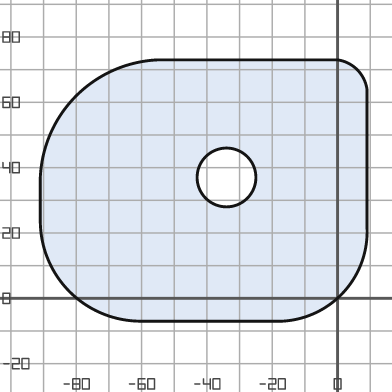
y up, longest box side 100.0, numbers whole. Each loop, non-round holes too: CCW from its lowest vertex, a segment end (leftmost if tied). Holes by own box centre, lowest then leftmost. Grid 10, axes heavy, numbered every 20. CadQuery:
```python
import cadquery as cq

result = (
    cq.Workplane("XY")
    .moveTo(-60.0, -7.0)
    .lineTo(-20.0, -7.0)
    .threePointArc((1.0, 1.0), (9.0, 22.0))
    .lineTo(9.0, 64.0)
    .threePointArc((6.0, 70.0), (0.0, 73.0))
    .lineTo(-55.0, 73.0)
    .threePointArc((-80.0, 62.0), (-91.0, 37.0))
    .lineTo(-91.0, 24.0)
    .threePointArc((-82.0, 2.0), (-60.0, -7.0))
    .close()
    .moveTo(-34.0, 37.0)
    .circle(9.0)
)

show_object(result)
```